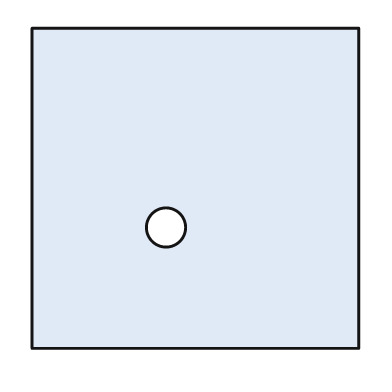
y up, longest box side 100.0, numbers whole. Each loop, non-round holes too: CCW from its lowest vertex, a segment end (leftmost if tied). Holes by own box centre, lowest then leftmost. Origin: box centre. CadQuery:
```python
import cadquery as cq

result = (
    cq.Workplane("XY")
    .moveTo(-50.0, -49.0)
    .lineTo(50.0, -49.0)
    .lineTo(50.0, 49.0)
    .lineTo(-50.0, 49.0)
    .close()
    .moveTo(-9.0, -12.0)
    .circle(6.0)
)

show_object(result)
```